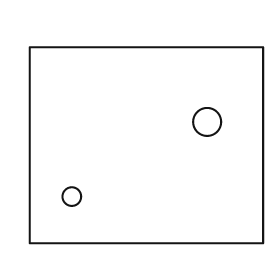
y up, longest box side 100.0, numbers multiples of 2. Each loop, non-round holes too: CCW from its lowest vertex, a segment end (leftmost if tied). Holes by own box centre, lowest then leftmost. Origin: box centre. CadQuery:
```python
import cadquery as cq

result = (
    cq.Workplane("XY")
    .moveTo(-50.0, -42.0)
    .lineTo(50.0, -42.0)
    .lineTo(50.0, 42.0)
    .lineTo(-50.0, 42.0)
    .close()
    .moveTo(-32.0, -22.0)
    .circle(4.0)
    .moveTo(26.0, 10.0)
    .circle(6.0)
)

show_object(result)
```